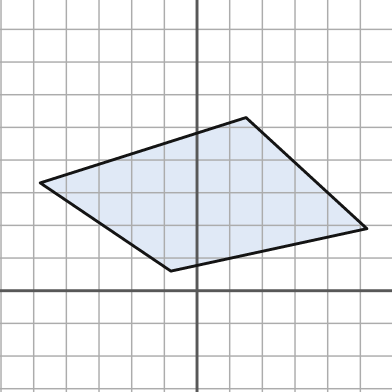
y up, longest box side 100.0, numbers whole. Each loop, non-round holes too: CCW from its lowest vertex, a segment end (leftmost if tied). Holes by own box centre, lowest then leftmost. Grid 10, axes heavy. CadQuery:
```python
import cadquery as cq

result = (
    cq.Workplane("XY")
    .moveTo(-8.0, 6.0)
    .lineTo(52.0, 19.0)
    .lineTo(15.0, 53.0)
    .lineTo(-48.0, 33.0)
    .close()
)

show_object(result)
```